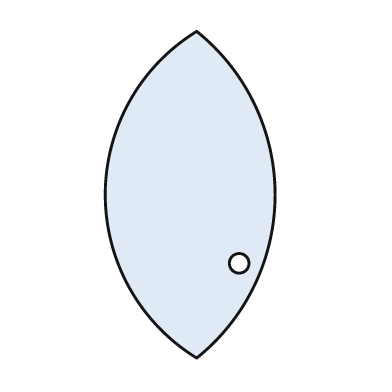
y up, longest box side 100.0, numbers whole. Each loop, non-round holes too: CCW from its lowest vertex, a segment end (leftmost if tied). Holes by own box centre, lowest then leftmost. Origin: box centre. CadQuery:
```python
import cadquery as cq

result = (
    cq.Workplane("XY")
    .moveTo(2.0, -50.0)
    .threePointArc((26.0, 0.0), (2.0, 50.0))
    .threePointArc((-26.0, 0.0), (2.0, -50.0))
    .close()
    .moveTo(15.0, -21.0)
    .circle(3.0)
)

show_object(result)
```